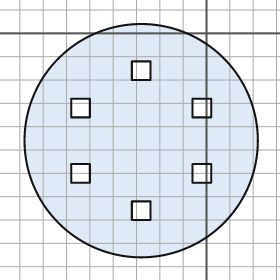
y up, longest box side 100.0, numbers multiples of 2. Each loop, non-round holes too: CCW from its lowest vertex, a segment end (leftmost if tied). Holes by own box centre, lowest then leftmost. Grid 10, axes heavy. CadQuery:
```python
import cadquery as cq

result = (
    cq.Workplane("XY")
    .moveTo(-28.0, -46.0)
    .circle(50.0)
    .moveTo(-32.0, -80.0)
    .lineTo(-24.0, -80.0)
    .lineTo(-24.0, -72.0)
    .lineTo(-32.0, -72.0)
    .close()
    .moveTo(-58.0, -64.0)
    .lineTo(-50.0, -64.0)
    .lineTo(-50.0, -56.0)
    .lineTo(-58.0, -56.0)
    .close()
    .moveTo(-6.0, -64.0)
    .lineTo(2.0, -64.0)
    .lineTo(2.0, -56.0)
    .lineTo(-6.0, -56.0)
    .close()
    .moveTo(-58.0, -36.0)
    .lineTo(-50.0, -36.0)
    .lineTo(-50.0, -28.0)
    .lineTo(-58.0, -28.0)
    .close()
    .moveTo(-6.0, -36.0)
    .lineTo(2.0, -36.0)
    .lineTo(2.0, -28.0)
    .lineTo(-6.0, -28.0)
    .close()
    .moveTo(-32.0, -20.0)
    .lineTo(-24.0, -20.0)
    .lineTo(-24.0, -12.0)
    .lineTo(-32.0, -12.0)
    .close()
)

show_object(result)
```